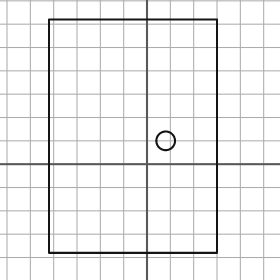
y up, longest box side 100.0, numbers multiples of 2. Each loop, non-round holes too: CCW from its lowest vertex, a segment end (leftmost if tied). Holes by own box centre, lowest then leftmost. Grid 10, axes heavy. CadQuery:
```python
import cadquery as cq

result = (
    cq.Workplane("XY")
    .moveTo(-42.0, -38.0)
    .lineTo(30.0, -38.0)
    .lineTo(30.0, 62.0)
    .lineTo(-42.0, 62.0)
    .close()
    .moveTo(8.0, 10.0)
    .circle(4.0)
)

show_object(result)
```